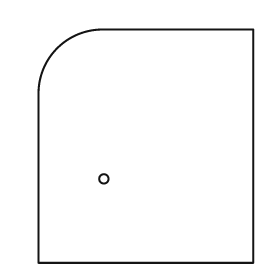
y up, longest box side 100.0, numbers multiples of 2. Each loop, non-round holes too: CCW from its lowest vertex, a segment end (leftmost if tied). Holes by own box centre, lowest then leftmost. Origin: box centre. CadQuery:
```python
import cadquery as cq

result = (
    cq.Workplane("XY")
    .moveTo(-46.0, -50.0)
    .lineTo(46.0, -50.0)
    .lineTo(46.0, 50.0)
    .lineTo(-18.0, 50.0)
    .threePointArc((-38.0, 42.0), (-46.0, 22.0))
    .close()
    .moveTo(-18.0, -14.0)
    .circle(2.0)
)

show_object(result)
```